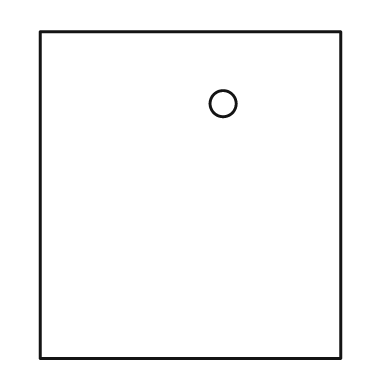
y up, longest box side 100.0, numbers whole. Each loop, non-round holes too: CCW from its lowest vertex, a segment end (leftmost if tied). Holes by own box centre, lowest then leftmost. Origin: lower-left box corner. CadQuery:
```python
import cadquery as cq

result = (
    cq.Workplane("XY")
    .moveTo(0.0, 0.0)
    .lineTo(92.0, 0.0)
    .lineTo(92.0, 100.0)
    .lineTo(0.0, 100.0)
    .close()
    .moveTo(56.0, 78.0)
    .circle(4.0)
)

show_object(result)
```